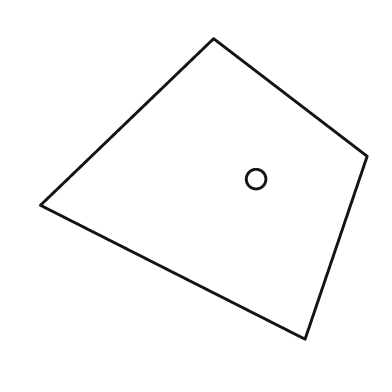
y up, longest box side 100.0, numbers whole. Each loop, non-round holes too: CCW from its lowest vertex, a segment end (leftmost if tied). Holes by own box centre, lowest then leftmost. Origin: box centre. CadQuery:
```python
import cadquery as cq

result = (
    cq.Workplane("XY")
    .moveTo(31.0, -46.0)
    .lineTo(50.0, 10.0)
    .lineTo(3.0, 46.0)
    .lineTo(-50.0, -5.0)
    .close()
    .moveTo(16.0, 3.0)
    .circle(3.0)
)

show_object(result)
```